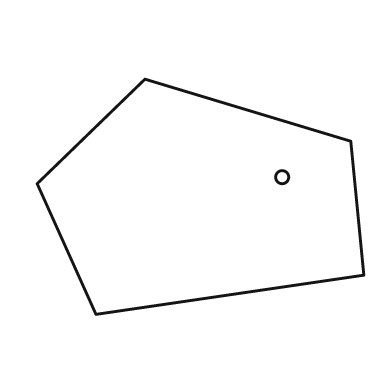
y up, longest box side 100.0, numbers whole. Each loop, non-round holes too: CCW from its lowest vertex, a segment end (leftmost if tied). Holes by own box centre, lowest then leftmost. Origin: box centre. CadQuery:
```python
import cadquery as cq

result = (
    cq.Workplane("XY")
    .moveTo(-32.0, -36.0)
    .lineTo(50.0, -24.0)
    .lineTo(46.0, 17.0)
    .lineTo(-17.0, 36.0)
    .lineTo(-50.0, 4.0)
    .close()
    .moveTo(25.0, 6.0)
    .circle(2.0)
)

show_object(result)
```